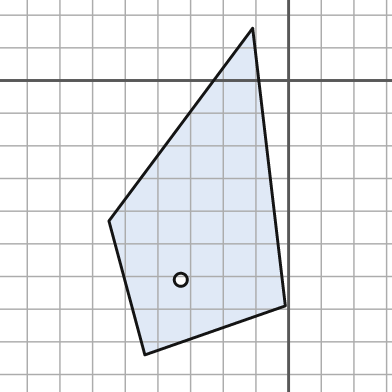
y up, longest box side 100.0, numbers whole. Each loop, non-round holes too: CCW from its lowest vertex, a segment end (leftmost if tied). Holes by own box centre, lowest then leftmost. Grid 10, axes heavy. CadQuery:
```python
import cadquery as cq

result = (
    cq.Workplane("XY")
    .moveTo(-44.0, -84.0)
    .lineTo(-1.0, -69.0)
    .lineTo(-11.0, 16.0)
    .lineTo(-55.0, -43.0)
    .close()
    .moveTo(-33.0, -61.0)
    .circle(2.0)
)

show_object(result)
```